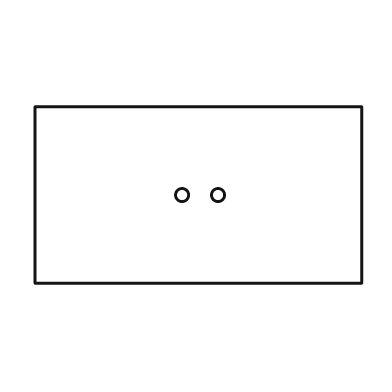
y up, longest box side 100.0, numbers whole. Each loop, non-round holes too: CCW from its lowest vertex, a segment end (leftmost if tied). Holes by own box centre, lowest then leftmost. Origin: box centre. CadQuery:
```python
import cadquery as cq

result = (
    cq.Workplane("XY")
    .moveTo(-50.0, -27.0)
    .lineTo(50.0, -27.0)
    .lineTo(50.0, 27.0)
    .lineTo(-50.0, 27.0)
    .close()
    .moveTo(-5.0, 0.0)
    .circle(2.0)
    .moveTo(6.0, 0.0)
    .circle(2.0)
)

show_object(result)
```